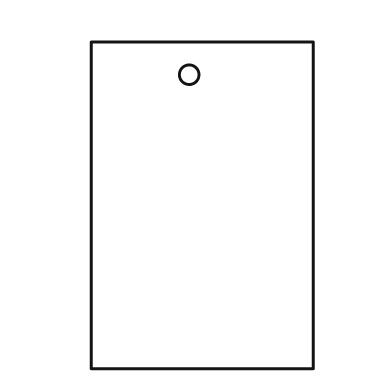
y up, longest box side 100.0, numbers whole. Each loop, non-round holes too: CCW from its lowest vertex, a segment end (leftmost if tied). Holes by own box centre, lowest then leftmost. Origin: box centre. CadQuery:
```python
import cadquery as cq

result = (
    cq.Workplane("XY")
    .moveTo(-34.0, -50.0)
    .lineTo(34.0, -50.0)
    .lineTo(34.0, 50.0)
    .lineTo(-34.0, 50.0)
    .close()
    .moveTo(-4.0, 40.0)
    .circle(3.0)
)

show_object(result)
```